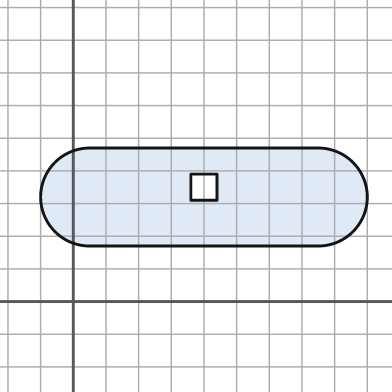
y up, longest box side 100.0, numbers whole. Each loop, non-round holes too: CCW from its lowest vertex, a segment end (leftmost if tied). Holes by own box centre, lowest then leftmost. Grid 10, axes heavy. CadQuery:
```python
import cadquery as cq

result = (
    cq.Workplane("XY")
    .moveTo(5.0, 17.0)
    .lineTo(75.0, 17.0)
    .threePointArc((90.0, 32.0), (75.0, 47.0))
    .lineTo(5.0, 47.0)
    .threePointArc((-10.0, 32.0), (5.0, 17.0))
    .close()
    .moveTo(36.0, 31.0)
    .lineTo(44.0, 31.0)
    .lineTo(44.0, 39.0)
    .lineTo(36.0, 39.0)
    .close()
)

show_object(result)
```